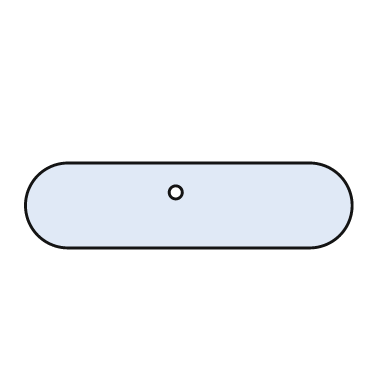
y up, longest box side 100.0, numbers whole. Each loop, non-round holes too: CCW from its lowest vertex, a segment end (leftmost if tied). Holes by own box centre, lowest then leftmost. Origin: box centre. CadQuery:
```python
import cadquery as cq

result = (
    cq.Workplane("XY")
    .moveTo(-37.0, -13.0)
    .lineTo(37.0, -13.0)
    .threePointArc((50.0, 0.0), (37.0, 13.0))
    .lineTo(-37.0, 13.0)
    .threePointArc((-50.0, 0.0), (-37.0, -13.0))
    .close()
    .moveTo(-4.0, 4.0)
    .circle(2.0)
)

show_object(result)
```